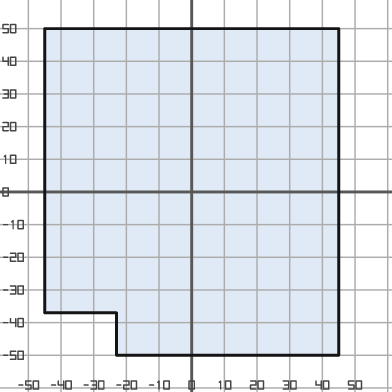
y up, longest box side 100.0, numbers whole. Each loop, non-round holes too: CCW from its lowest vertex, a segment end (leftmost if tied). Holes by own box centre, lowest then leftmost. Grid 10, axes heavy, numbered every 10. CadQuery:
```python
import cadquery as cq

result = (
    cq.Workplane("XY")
    .moveTo(-23.0, -50.0)
    .lineTo(45.0, -50.0)
    .lineTo(45.0, 50.0)
    .lineTo(-45.0, 50.0)
    .lineTo(-45.0, -37.0)
    .lineTo(-23.0, -37.0)
    .close()
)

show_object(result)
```